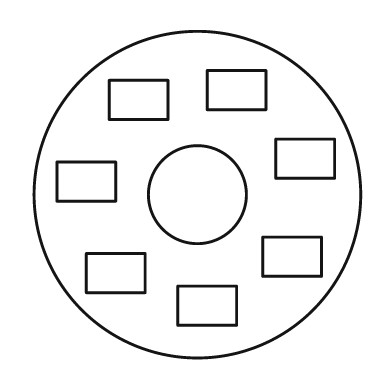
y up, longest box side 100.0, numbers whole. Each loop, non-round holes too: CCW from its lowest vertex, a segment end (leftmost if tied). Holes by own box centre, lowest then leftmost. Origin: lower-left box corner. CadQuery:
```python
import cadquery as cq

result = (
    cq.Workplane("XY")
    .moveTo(50.0, 50.0)
    .circle(50.0)
    .moveTo(44.0, 10.0)
    .lineTo(62.0, 10.0)
    .lineTo(62.0, 22.0)
    .lineTo(44.0, 22.0)
    .close()
    .moveTo(16.0, 20.0)
    .lineTo(34.0, 20.0)
    .lineTo(34.0, 32.0)
    .lineTo(16.0, 32.0)
    .close()
    .moveTo(70.0, 25.0)
    .lineTo(88.0, 25.0)
    .lineTo(88.0, 37.0)
    .lineTo(70.0, 37.0)
    .close()
    .moveTo(50.0, 50.0)
    .circle(15.0)
    .moveTo(7.0, 48.0)
    .lineTo(25.0, 48.0)
    .lineTo(25.0, 60.0)
    .lineTo(7.0, 60.0)
    .close()
    .moveTo(74.0, 55.0)
    .lineTo(92.0, 55.0)
    .lineTo(92.0, 67.0)
    .lineTo(74.0, 67.0)
    .close()
    .moveTo(23.0, 73.0)
    .lineTo(41.0, 73.0)
    .lineTo(41.0, 85.0)
    .lineTo(23.0, 85.0)
    .close()
    .moveTo(53.0, 76.0)
    .lineTo(71.0, 76.0)
    .lineTo(71.0, 88.0)
    .lineTo(53.0, 88.0)
    .close()
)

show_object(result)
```